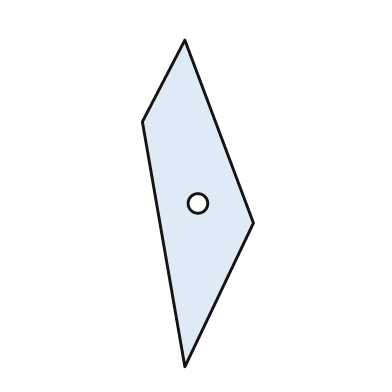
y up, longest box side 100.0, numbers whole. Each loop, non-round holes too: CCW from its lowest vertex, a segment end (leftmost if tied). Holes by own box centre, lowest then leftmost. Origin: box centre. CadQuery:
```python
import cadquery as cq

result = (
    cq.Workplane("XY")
    .moveTo(-4.0, -50.0)
    .lineTo(17.0, -6.0)
    .lineTo(-4.0, 50.0)
    .lineTo(-17.0, 25.0)
    .close()
    .moveTo(0.0, 0.0)
    .circle(3.0)
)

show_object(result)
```